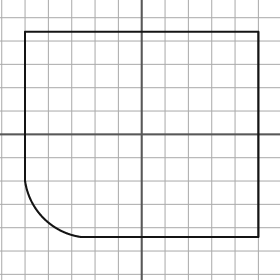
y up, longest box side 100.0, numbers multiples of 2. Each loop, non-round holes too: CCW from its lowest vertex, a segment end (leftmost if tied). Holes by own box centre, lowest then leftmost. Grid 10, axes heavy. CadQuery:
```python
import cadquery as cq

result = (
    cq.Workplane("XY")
    .moveTo(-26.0, -44.0)
    .lineTo(50.0, -44.0)
    .lineTo(50.0, 44.0)
    .lineTo(-50.0, 44.0)
    .lineTo(-50.0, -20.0)
    .threePointArc((-42.0, -36.0), (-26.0, -44.0))
    .close()
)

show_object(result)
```